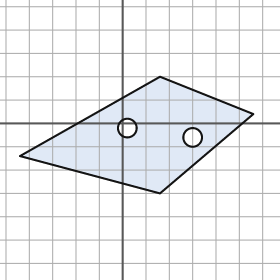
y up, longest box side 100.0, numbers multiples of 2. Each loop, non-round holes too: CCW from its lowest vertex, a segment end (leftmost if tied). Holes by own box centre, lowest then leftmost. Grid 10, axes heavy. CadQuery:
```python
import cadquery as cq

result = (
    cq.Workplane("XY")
    .moveTo(16.0, -30.0)
    .lineTo(56.0, 4.0)
    .lineTo(16.0, 20.0)
    .lineTo(-44.0, -14.0)
    .close()
    .moveTo(30.0, -6.0)
    .circle(4.0)
    .moveTo(2.0, -2.0)
    .circle(4.0)
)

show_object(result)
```